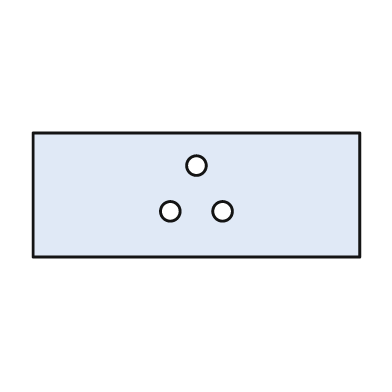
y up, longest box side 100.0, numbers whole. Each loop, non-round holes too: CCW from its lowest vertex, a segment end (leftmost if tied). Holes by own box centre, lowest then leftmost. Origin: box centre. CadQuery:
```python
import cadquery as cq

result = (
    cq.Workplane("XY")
    .moveTo(-50.0, -19.0)
    .lineTo(50.0, -19.0)
    .lineTo(50.0, 19.0)
    .lineTo(-50.0, 19.0)
    .close()
    .moveTo(-8.0, -5.0)
    .circle(3.0)
    .moveTo(8.0, -5.0)
    .circle(3.0)
    .moveTo(0.0, 9.0)
    .circle(3.0)
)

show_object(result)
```